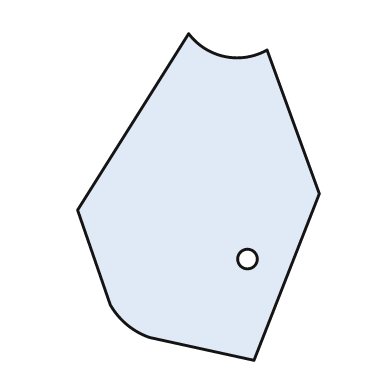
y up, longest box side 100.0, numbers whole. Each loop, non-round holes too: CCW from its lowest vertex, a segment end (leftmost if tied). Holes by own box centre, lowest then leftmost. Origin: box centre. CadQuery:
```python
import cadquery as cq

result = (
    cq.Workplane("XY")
    .moveTo(17.0, -50.0)
    .lineTo(37.0, 1.0)
    .lineTo(21.0, 45.0)
    .threePointArc((8.0, 43.0), (-3.0, 50.0))
    .lineTo(-37.0, -4.0)
    .lineTo(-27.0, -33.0)
    .threePointArc((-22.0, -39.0), (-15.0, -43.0))
    .close()
    .moveTo(15.0, -19.0)
    .circle(3.0)
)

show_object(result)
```